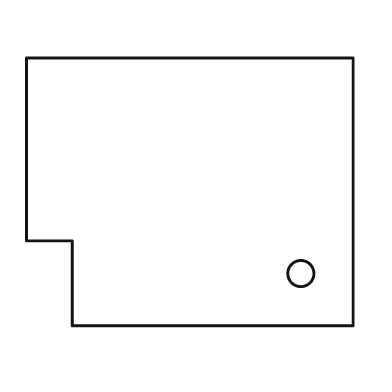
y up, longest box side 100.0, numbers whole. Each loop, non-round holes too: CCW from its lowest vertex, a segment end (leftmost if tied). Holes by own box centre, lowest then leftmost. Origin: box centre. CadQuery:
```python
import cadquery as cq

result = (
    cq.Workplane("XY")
    .moveTo(-36.0, -41.0)
    .lineTo(50.0, -41.0)
    .lineTo(50.0, 41.0)
    .lineTo(-50.0, 41.0)
    .lineTo(-50.0, -15.0)
    .lineTo(-36.0, -15.0)
    .close()
    .moveTo(34.0, -25.0)
    .circle(4.0)
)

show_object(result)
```